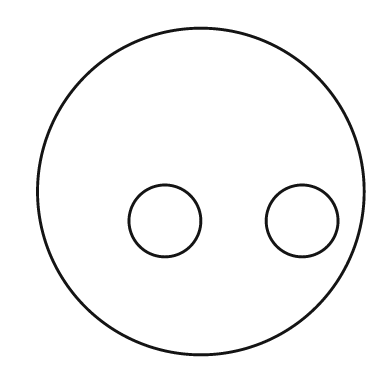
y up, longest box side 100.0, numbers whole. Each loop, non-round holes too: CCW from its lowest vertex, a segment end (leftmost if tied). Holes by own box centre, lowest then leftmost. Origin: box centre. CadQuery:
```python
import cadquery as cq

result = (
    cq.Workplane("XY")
    .moveTo(0.0, 0.0)
    .circle(50.0)
    .moveTo(-11.0, -9.0)
    .circle(11.0)
    .moveTo(31.0, -9.0)
    .circle(11.0)
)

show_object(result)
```